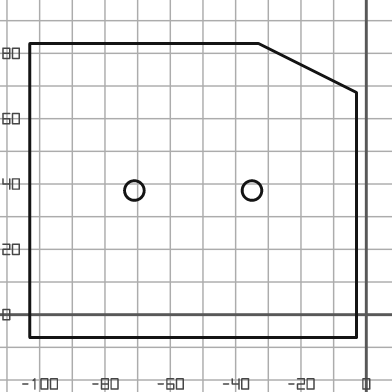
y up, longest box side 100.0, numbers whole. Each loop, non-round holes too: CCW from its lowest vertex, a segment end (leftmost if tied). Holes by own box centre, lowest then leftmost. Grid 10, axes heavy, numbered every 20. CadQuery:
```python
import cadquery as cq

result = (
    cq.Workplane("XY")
    .moveTo(-103.0, -7.0)
    .lineTo(-3.0, -7.0)
    .lineTo(-3.0, 68.0)
    .lineTo(-33.0, 83.0)
    .lineTo(-103.0, 83.0)
    .close()
    .moveTo(-71.0, 38.0)
    .circle(3.0)
    .moveTo(-35.0, 38.0)
    .circle(3.0)
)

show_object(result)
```